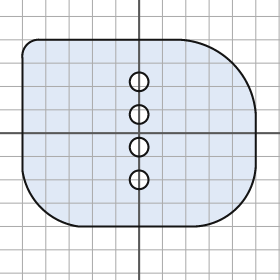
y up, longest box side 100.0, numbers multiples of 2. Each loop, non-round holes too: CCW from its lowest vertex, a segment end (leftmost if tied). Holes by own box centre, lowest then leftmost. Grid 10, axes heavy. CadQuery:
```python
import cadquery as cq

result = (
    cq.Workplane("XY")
    .moveTo(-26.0, -40.0)
    .lineTo(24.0, -40.0)
    .threePointArc((42.0, -32.0), (50.0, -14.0))
    .lineTo(50.0, 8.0)
    .threePointArc((40.0, 30.0), (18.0, 40.0))
    .lineTo(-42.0, 40.0)
    .threePointArc((-48.0, 38.0), (-50.0, 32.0))
    .lineTo(-50.0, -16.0)
    .threePointArc((-42.0, -32.0), (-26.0, -40.0))
    .close()
    .moveTo(0.0, -20.0)
    .circle(4.0)
    .moveTo(0.0, -6.0)
    .circle(4.0)
    .moveTo(0.0, 8.0)
    .circle(4.0)
    .moveTo(0.0, 22.0)
    .circle(4.0)
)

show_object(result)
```